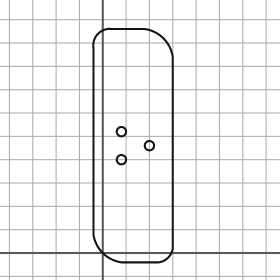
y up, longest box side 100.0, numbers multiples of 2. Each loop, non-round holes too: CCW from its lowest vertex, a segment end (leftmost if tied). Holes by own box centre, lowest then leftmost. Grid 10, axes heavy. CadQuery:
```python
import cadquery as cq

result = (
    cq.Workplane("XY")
    .moveTo(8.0, -4.0)
    .lineTo(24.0, -4.0)
    .threePointArc((28.0, -2.0), (30.0, 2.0))
    .lineTo(30.0, 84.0)
    .threePointArc((26.0, 92.0), (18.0, 96.0))
    .lineTo(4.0, 96.0)
    .threePointArc((-2.0, 94.0), (-4.0, 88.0))
    .lineTo(-4.0, 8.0)
    .threePointArc((0.0, 0.0), (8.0, -4.0))
    .close()
    .moveTo(8.0, 40.0)
    .circle(2.0)
    .moveTo(20.0, 46.0)
    .circle(2.0)
    .moveTo(8.0, 52.0)
    .circle(2.0)
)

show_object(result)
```